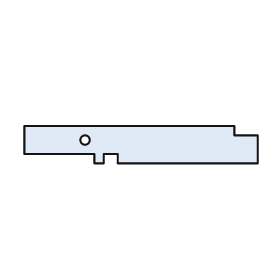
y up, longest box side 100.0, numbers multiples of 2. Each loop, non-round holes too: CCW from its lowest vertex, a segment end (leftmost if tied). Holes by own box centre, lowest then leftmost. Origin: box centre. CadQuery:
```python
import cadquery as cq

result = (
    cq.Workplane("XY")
    .moveTo(-20.0, -8.0)
    .lineTo(-16.0, -8.0)
    .lineTo(-16.0, -4.0)
    .lineTo(-10.0, -4.0)
    .lineTo(-10.0, -8.0)
    .lineTo(50.0, -8.0)
    .lineTo(50.0, 4.0)
    .lineTo(40.0, 4.0)
    .lineTo(40.0, 8.0)
    .lineTo(-50.0, 8.0)
    .lineTo(-50.0, -4.0)
    .lineTo(-20.0, -4.0)
    .close()
    .moveTo(-24.0, 2.0)
    .circle(2.0)
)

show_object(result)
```